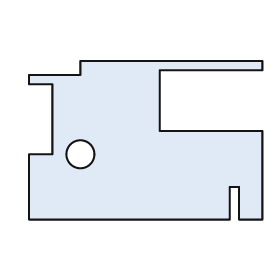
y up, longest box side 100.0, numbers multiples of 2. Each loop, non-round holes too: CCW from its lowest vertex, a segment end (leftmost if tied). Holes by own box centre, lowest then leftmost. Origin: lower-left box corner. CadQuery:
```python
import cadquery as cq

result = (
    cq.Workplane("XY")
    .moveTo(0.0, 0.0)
    .lineTo(86.0, 0.0)
    .lineTo(86.0, 14.0)
    .lineTo(90.0, 14.0)
    .lineTo(90.0, 0.0)
    .lineTo(100.0, 0.0)
    .lineTo(100.0, 38.0)
    .lineTo(56.0, 38.0)
    .lineTo(56.0, 64.0)
    .lineTo(100.0, 64.0)
    .lineTo(100.0, 68.0)
    .lineTo(22.0, 68.0)
    .lineTo(22.0, 62.0)
    .lineTo(0.0, 62.0)
    .lineTo(0.0, 58.0)
    .lineTo(10.0, 58.0)
    .lineTo(10.0, 28.0)
    .lineTo(0.0, 28.0)
    .close()
    .moveTo(22.0, 28.0)
    .circle(6.0)
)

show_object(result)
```